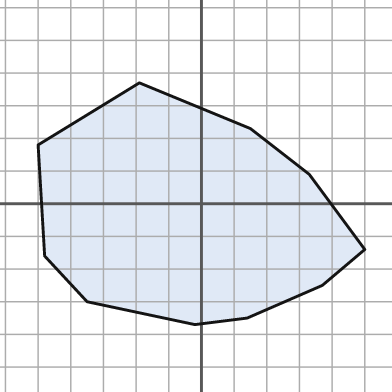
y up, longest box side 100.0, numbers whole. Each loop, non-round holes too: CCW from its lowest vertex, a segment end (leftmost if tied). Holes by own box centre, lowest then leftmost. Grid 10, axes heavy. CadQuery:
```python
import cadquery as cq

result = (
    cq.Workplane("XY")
    .moveTo(-2.0, -37.0)
    .lineTo(14.0, -35.0)
    .lineTo(37.0, -25.0)
    .lineTo(50.0, -14.0)
    .lineTo(33.0, 9.0)
    .lineTo(15.0, 23.0)
    .lineTo(-19.0, 37.0)
    .lineTo(-50.0, 18.0)
    .lineTo(-48.0, -16.0)
    .lineTo(-35.0, -30.0)
    .close()
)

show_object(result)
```